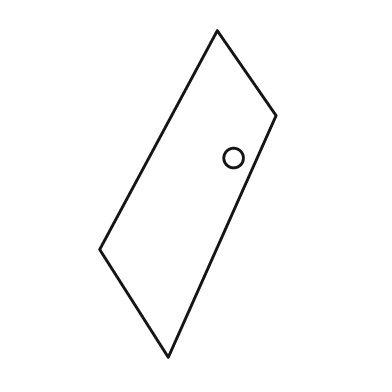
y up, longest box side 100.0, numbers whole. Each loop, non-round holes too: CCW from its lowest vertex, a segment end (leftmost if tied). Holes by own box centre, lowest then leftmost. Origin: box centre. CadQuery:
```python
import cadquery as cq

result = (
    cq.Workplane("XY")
    .moveTo(-6.0, -50.0)
    .lineTo(27.0, 24.0)
    .lineTo(9.0, 50.0)
    .lineTo(-27.0, -17.0)
    .close()
    .moveTo(14.0, 11.0)
    .circle(3.0)
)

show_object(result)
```